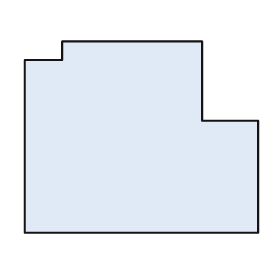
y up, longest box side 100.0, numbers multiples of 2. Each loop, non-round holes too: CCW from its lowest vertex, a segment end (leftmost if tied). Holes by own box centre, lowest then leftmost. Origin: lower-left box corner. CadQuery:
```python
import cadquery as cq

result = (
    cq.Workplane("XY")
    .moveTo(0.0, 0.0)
    .lineTo(100.0, 0.0)
    .lineTo(100.0, 48.0)
    .lineTo(76.0, 48.0)
    .lineTo(76.0, 82.0)
    .lineTo(16.0, 82.0)
    .lineTo(16.0, 74.0)
    .lineTo(0.0, 74.0)
    .close()
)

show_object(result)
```